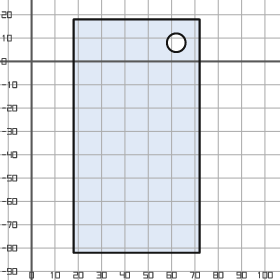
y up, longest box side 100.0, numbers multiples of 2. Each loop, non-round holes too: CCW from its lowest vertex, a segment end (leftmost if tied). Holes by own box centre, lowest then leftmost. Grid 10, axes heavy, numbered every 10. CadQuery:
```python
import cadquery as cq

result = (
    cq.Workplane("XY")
    .moveTo(18.0, -82.0)
    .lineTo(72.0, -82.0)
    .lineTo(72.0, 18.0)
    .lineTo(18.0, 18.0)
    .close()
    .moveTo(62.0, 8.0)
    .circle(4.0)
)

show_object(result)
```